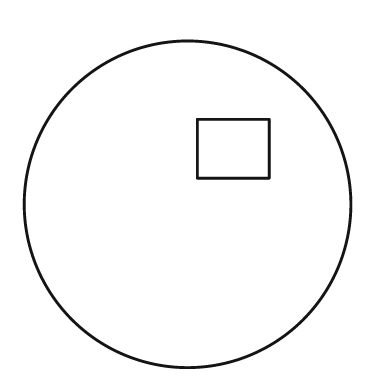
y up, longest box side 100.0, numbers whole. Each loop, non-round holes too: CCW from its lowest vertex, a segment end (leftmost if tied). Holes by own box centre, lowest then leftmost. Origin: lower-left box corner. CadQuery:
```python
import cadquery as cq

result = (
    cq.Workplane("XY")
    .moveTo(50.0, 50.0)
    .circle(50.0)
    .moveTo(53.0, 58.0)
    .lineTo(75.0, 58.0)
    .lineTo(75.0, 76.0)
    .lineTo(53.0, 76.0)
    .close()
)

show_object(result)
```